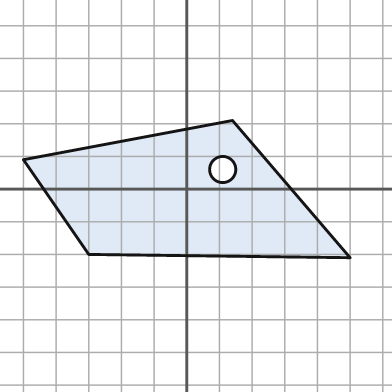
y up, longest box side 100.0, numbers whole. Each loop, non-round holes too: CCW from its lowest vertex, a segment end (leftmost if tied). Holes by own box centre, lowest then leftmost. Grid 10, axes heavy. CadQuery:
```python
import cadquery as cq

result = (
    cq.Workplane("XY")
    .moveTo(50.0, -21.0)
    .lineTo(14.0, 21.0)
    .lineTo(-50.0, 9.0)
    .lineTo(-30.0, -20.0)
    .close()
    .moveTo(11.0, 6.0)
    .circle(4.0)
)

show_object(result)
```